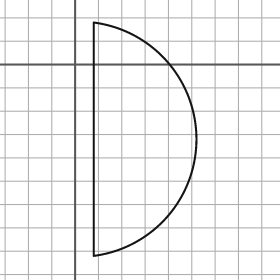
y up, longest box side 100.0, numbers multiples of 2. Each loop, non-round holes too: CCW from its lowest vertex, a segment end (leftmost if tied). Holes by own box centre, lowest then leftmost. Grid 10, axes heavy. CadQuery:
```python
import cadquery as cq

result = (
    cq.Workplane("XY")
    .moveTo(8.0, -82.0)
    .threePointArc((52.0, -32.0), (8.0, 18.0))
    .close()
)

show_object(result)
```